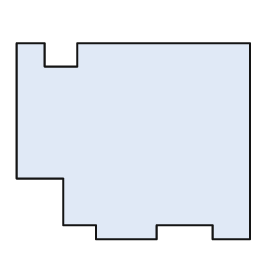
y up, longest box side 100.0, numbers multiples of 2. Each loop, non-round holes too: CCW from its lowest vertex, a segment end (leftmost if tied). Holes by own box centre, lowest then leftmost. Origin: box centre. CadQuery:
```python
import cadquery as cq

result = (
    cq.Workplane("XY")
    .moveTo(-16.0, -42.0)
    .lineTo(10.0, -42.0)
    .lineTo(10.0, -36.0)
    .lineTo(34.0, -36.0)
    .lineTo(34.0, -42.0)
    .lineTo(50.0, -42.0)
    .lineTo(50.0, 42.0)
    .lineTo(-24.0, 42.0)
    .lineTo(-24.0, 32.0)
    .lineTo(-38.0, 32.0)
    .lineTo(-38.0, 42.0)
    .lineTo(-50.0, 42.0)
    .lineTo(-50.0, -16.0)
    .lineTo(-30.0, -16.0)
    .lineTo(-30.0, -36.0)
    .lineTo(-16.0, -36.0)
    .close()
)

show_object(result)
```